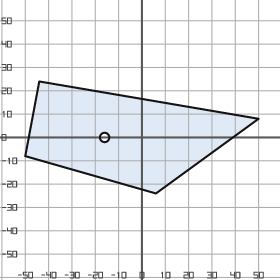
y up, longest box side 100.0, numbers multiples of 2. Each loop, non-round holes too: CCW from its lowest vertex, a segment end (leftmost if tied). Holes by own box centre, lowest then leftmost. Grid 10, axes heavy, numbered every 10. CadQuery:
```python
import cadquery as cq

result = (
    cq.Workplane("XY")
    .moveTo(6.0, -24.0)
    .lineTo(50.0, 8.0)
    .lineTo(-44.0, 24.0)
    .lineTo(-50.0, -8.0)
    .close()
    .moveTo(-16.0, 0.0)
    .circle(2.0)
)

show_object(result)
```